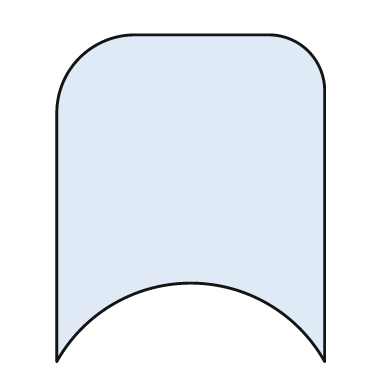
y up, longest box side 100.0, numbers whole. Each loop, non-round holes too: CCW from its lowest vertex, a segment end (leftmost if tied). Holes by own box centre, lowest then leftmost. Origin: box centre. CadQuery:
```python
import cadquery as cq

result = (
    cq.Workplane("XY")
    .moveTo(-41.0, -50.0)
    .threePointArc((0.0, -26.0), (41.0, -50.0))
    .lineTo(41.0, 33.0)
    .threePointArc((36.0, 45.0), (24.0, 50.0))
    .lineTo(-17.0, 50.0)
    .threePointArc((-34.0, 43.0), (-41.0, 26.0))
    .close()
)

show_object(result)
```